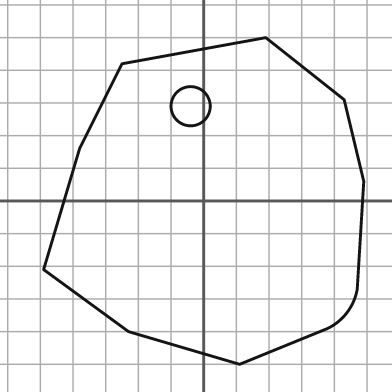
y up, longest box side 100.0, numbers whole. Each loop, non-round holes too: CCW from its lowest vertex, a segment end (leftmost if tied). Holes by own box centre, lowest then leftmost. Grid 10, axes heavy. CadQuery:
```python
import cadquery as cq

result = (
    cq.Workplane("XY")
    .moveTo(11.0, -50.0)
    .lineTo(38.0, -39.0)
    .threePointArc((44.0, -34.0), (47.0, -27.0))
    .lineTo(49.0, 6.0)
    .lineTo(43.0, 31.0)
    .lineTo(19.0, 50.0)
    .lineTo(-25.0, 42.0)
    .lineTo(-38.0, 16.0)
    .lineTo(-49.0, -21.0)
    .lineTo(-23.0, -40.0)
    .close()
    .moveTo(-4.0, 29.0)
    .circle(6.0)
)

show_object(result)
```